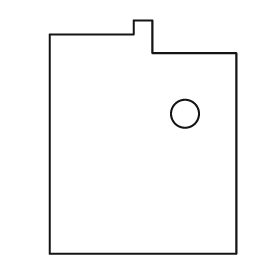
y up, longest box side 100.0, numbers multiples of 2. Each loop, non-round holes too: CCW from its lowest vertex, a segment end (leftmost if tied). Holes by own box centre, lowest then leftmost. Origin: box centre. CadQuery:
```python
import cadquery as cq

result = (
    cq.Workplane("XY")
    .moveTo(-40.0, -50.0)
    .lineTo(40.0, -50.0)
    .lineTo(40.0, 36.0)
    .lineTo(4.0, 36.0)
    .lineTo(4.0, 50.0)
    .lineTo(-4.0, 50.0)
    .lineTo(-4.0, 44.0)
    .lineTo(-40.0, 44.0)
    .close()
    .moveTo(18.0, 10.0)
    .circle(6.0)
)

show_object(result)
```